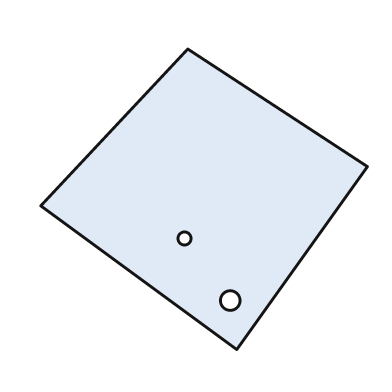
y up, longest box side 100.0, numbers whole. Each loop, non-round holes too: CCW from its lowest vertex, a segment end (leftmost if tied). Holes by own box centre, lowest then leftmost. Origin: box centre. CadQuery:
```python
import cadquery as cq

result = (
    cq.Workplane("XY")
    .moveTo(10.0, -46.0)
    .lineTo(50.0, 10.0)
    .lineTo(-5.0, 46.0)
    .lineTo(-50.0, -2.0)
    .close()
    .moveTo(8.0, -31.0)
    .circle(3.0)
    .moveTo(-6.0, -12.0)
    .circle(2.0)
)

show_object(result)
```